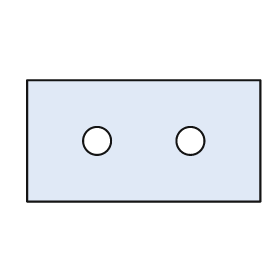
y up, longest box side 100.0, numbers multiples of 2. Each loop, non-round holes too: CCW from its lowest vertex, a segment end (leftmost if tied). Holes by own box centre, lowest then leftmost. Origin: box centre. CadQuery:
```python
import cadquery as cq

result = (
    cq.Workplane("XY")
    .moveTo(-50.0, -26.0)
    .lineTo(50.0, -26.0)
    .lineTo(50.0, 26.0)
    .lineTo(-50.0, 26.0)
    .close()
    .moveTo(-20.0, 0.0)
    .circle(6.0)
    .moveTo(20.0, 0.0)
    .circle(6.0)
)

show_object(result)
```